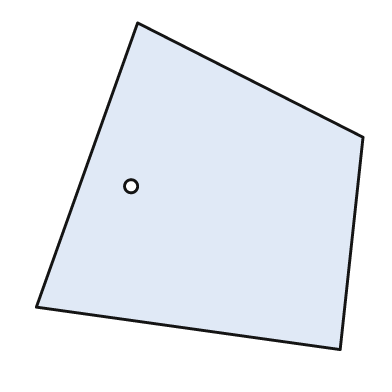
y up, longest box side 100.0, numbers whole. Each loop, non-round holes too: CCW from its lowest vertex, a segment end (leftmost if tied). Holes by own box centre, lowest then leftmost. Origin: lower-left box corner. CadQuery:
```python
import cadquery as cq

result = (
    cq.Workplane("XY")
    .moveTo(93.0, 0.0)
    .lineTo(100.0, 65.0)
    .lineTo(31.0, 100.0)
    .lineTo(0.0, 13.0)
    .close()
    .moveTo(29.0, 50.0)
    .circle(2.0)
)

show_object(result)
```